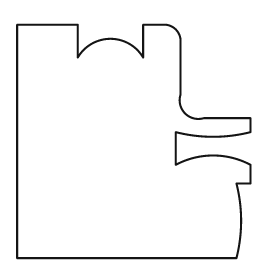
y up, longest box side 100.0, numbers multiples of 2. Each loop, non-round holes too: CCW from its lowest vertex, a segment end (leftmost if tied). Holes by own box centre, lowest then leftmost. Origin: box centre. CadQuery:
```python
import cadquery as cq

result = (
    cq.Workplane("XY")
    .moveTo(-50.0, -50.0)
    .lineTo(44.0, -50.0)
    .threePointArc((46.0, -34.0), (44.0, -18.0))
    .lineTo(50.0, -18.0)
    .lineTo(50.0, -10.0)
    .threePointArc((34.0, -6.0), (18.0, -10.0))
    .lineTo(18.0, 4.0)
    .threePointArc((34.0, 2.0), (50.0, 4.0))
    .lineTo(50.0, 10.0)
    .lineTo(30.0, 10.0)
    .threePointArc((22.0, 12.0), (20.0, 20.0))
    .lineTo(20.0, 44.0)
    .threePointArc((18.0, 48.0), (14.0, 50.0))
    .lineTo(4.0, 50.0)
    .lineTo(4.0, 36.0)
    .threePointArc((-10.0, 44.0), (-24.0, 36.0))
    .lineTo(-24.0, 50.0)
    .lineTo(-50.0, 50.0)
    .close()
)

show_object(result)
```